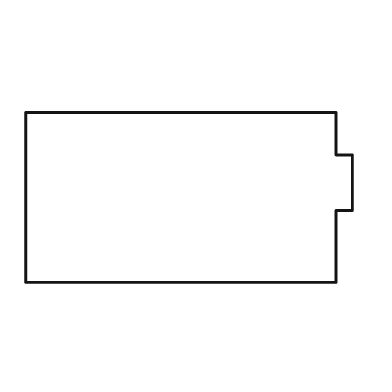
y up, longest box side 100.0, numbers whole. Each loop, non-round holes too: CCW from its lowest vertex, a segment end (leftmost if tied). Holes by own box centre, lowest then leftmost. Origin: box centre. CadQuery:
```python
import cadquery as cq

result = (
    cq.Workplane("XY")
    .moveTo(-50.0, -26.0)
    .lineTo(45.0, -26.0)
    .lineTo(45.0, -4.0)
    .lineTo(50.0, -4.0)
    .lineTo(50.0, 13.0)
    .lineTo(45.0, 13.0)
    .lineTo(45.0, 26.0)
    .lineTo(-50.0, 26.0)
    .close()
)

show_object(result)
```